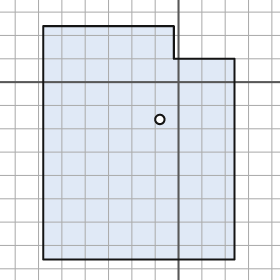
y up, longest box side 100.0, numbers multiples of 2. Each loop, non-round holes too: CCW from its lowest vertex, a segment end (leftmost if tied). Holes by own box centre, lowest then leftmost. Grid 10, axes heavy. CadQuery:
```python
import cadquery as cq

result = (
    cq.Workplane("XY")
    .moveTo(-58.0, -76.0)
    .lineTo(24.0, -76.0)
    .lineTo(24.0, 10.0)
    .lineTo(-2.0, 10.0)
    .lineTo(-2.0, 24.0)
    .lineTo(-58.0, 24.0)
    .close()
    .moveTo(-8.0, -16.0)
    .circle(2.0)
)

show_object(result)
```